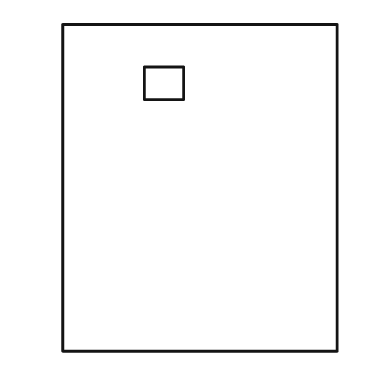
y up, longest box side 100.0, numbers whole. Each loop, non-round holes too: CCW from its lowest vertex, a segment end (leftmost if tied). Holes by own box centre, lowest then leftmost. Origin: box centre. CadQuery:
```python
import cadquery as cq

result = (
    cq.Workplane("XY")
    .moveTo(-42.0, -50.0)
    .lineTo(42.0, -50.0)
    .lineTo(42.0, 50.0)
    .lineTo(-42.0, 50.0)
    .close()
    .moveTo(-17.0, 27.0)
    .lineTo(-5.0, 27.0)
    .lineTo(-5.0, 37.0)
    .lineTo(-17.0, 37.0)
    .close()
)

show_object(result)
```